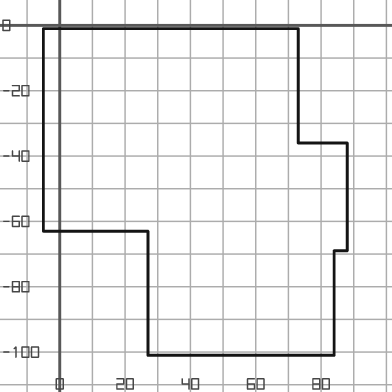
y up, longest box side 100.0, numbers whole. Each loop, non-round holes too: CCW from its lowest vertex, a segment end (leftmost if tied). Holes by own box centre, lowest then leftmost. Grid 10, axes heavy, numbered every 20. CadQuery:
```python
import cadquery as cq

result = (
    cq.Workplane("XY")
    .moveTo(27.0, -101.0)
    .lineTo(84.0, -101.0)
    .lineTo(84.0, -69.0)
    .lineTo(88.0, -69.0)
    .lineTo(88.0, -36.0)
    .lineTo(73.0, -36.0)
    .lineTo(73.0, -1.0)
    .lineTo(-5.0, -1.0)
    .lineTo(-5.0, -63.0)
    .lineTo(27.0, -63.0)
    .close()
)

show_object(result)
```